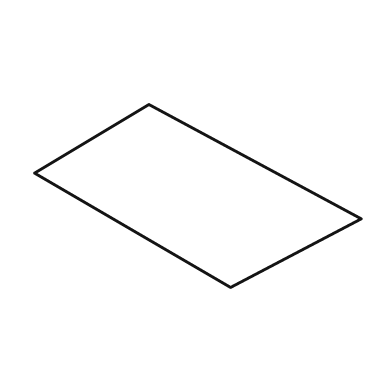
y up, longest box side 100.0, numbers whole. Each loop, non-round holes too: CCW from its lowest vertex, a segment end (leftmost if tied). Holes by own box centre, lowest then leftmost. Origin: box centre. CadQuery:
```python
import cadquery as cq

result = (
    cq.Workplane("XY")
    .moveTo(10.0, -28.0)
    .lineTo(50.0, -7.0)
    .lineTo(-15.0, 28.0)
    .lineTo(-50.0, 7.0)
    .close()
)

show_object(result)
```